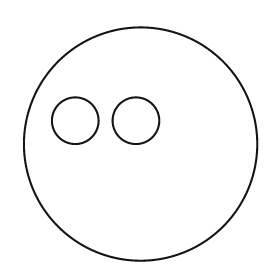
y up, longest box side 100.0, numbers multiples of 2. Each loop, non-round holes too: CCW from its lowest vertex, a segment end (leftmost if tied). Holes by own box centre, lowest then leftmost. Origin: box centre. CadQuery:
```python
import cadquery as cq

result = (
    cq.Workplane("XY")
    .moveTo(0.0, 0.0)
    .circle(50.0)
    .moveTo(-28.0, 10.0)
    .circle(10.0)
    .moveTo(-2.0, 10.0)
    .circle(10.0)
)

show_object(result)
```